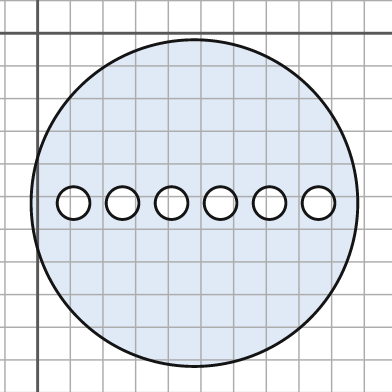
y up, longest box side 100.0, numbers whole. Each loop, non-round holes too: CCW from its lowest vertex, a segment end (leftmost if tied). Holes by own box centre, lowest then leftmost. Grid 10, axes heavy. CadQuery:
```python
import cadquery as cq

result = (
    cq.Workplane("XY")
    .moveTo(48.0, -52.0)
    .circle(50.0)
    .moveTo(11.0, -52.0)
    .circle(5.0)
    .moveTo(26.0, -52.0)
    .circle(5.0)
    .moveTo(41.0, -52.0)
    .circle(5.0)
    .moveTo(56.0, -52.0)
    .circle(5.0)
    .moveTo(71.0, -52.0)
    .circle(5.0)
    .moveTo(86.0, -52.0)
    .circle(5.0)
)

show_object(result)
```